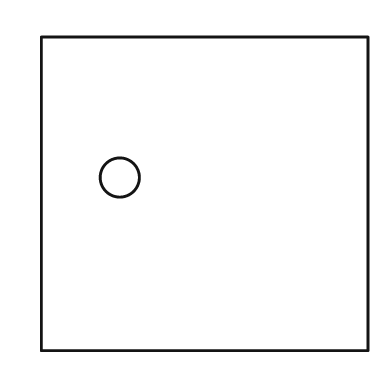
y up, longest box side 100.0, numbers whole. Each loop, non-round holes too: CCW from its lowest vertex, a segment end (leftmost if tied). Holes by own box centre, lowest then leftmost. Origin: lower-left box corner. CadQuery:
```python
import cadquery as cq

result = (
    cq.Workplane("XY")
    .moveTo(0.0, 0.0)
    .lineTo(100.0, 0.0)
    .lineTo(100.0, 96.0)
    .lineTo(0.0, 96.0)
    .close()
    .moveTo(24.0, 53.0)
    .circle(6.0)
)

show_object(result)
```